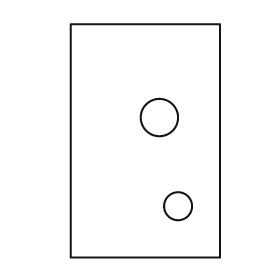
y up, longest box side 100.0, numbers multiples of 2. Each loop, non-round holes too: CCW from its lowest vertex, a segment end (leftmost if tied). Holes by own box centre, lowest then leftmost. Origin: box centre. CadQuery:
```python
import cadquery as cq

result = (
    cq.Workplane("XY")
    .moveTo(-32.0, -50.0)
    .lineTo(32.0, -50.0)
    .lineTo(32.0, 50.0)
    .lineTo(-32.0, 50.0)
    .close()
    .moveTo(14.0, -28.0)
    .circle(6.0)
    .moveTo(6.0, 10.0)
    .circle(8.0)
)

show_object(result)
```